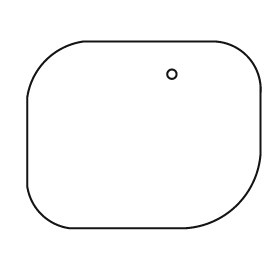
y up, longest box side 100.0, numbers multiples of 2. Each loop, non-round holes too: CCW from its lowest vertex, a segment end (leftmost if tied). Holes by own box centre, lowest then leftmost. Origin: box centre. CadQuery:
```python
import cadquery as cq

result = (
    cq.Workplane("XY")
    .moveTo(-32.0, -40.0)
    .lineTo(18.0, -40.0)
    .threePointArc((40.0, -30.0), (50.0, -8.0))
    .lineTo(50.0, 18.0)
    .threePointArc((44.0, 34.0), (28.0, 40.0))
    .lineTo(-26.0, 40.0)
    .threePointArc((-42.0, 32.0), (-50.0, 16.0))
    .lineTo(-50.0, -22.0)
    .threePointArc((-44.0, -34.0), (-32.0, -40.0))
    .close()
    .moveTo(12.0, 26.0)
    .circle(2.0)
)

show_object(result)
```